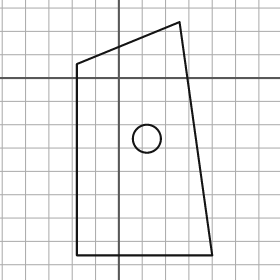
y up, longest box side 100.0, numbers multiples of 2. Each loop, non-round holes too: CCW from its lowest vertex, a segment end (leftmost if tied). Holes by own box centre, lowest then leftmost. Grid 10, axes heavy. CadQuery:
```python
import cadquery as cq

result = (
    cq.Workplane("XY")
    .moveTo(-18.0, -76.0)
    .lineTo(40.0, -76.0)
    .lineTo(26.0, 24.0)
    .lineTo(-18.0, 6.0)
    .close()
    .moveTo(12.0, -26.0)
    .circle(6.0)
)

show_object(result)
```